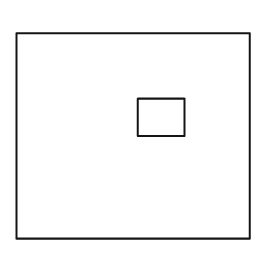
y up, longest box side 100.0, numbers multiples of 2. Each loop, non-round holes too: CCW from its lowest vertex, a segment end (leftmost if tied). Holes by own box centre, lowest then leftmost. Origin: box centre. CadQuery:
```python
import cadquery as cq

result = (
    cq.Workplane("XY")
    .moveTo(-50.0, -44.0)
    .lineTo(50.0, -44.0)
    .lineTo(50.0, 44.0)
    .lineTo(-50.0, 44.0)
    .close()
    .moveTo(2.0, 0.0)
    .lineTo(22.0, 0.0)
    .lineTo(22.0, 16.0)
    .lineTo(2.0, 16.0)
    .close()
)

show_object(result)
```